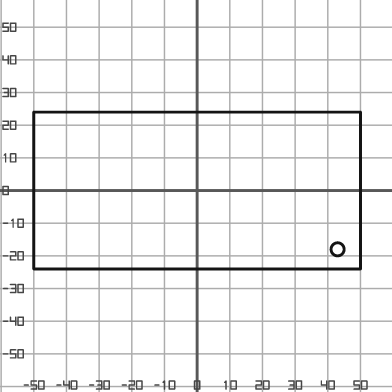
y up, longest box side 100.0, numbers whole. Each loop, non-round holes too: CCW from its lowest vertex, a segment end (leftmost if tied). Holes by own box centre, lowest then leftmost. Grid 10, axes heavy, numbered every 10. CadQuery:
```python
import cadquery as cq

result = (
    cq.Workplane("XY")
    .moveTo(-50.0, -24.0)
    .lineTo(50.0, -24.0)
    .lineTo(50.0, 24.0)
    .lineTo(-50.0, 24.0)
    .close()
    .moveTo(43.0, -18.0)
    .circle(2.0)
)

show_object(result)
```